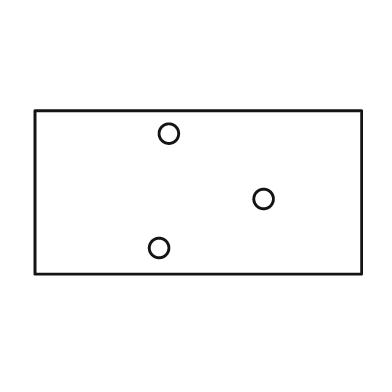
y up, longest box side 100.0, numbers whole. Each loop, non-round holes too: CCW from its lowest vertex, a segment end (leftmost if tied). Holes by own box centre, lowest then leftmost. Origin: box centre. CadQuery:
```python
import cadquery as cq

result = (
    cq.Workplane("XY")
    .moveTo(-50.0, -25.0)
    .lineTo(50.0, -25.0)
    .lineTo(50.0, 25.0)
    .lineTo(-50.0, 25.0)
    .close()
    .moveTo(-12.0, -17.0)
    .circle(3.0)
    .moveTo(20.0, -2.0)
    .circle(3.0)
    .moveTo(-9.0, 18.0)
    .circle(3.0)
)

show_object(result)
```